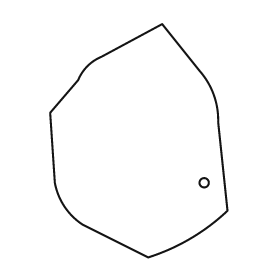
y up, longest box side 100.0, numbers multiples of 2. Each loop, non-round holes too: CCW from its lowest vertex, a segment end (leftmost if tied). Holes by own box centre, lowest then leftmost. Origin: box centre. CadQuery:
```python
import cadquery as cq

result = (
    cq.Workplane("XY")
    .moveTo(4.0, -50.0)
    .threePointArc((22.0, -42.0), (38.0, -30.0))
    .lineTo(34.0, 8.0)
    .threePointArc((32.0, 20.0), (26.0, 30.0))
    .lineTo(10.0, 50.0)
    .lineTo(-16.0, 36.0)
    .threePointArc((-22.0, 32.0), (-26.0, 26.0))
    .lineTo(-38.0, 12.0)
    .lineTo(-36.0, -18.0)
    .threePointArc((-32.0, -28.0), (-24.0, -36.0))
    .close()
    .moveTo(28.0, -18.0)
    .circle(2.0)
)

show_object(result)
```